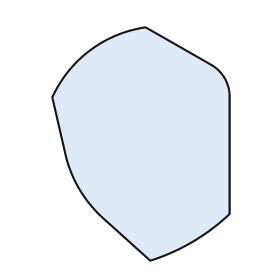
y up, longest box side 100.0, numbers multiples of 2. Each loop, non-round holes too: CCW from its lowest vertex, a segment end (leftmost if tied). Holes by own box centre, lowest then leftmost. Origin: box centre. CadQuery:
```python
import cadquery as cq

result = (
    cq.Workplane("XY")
    .moveTo(4.0, -50.0)
    .threePointArc((22.0, -42.0), (38.0, -30.0))
    .lineTo(38.0, 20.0)
    .threePointArc((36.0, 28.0), (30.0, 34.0))
    .lineTo(2.0, 50.0)
    .threePointArc((-22.0, 40.0), (-38.0, 20.0))
    .lineTo(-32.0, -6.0)
    .threePointArc((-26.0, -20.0), (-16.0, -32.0))
    .close()
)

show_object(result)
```